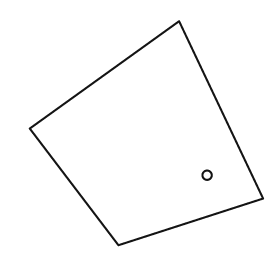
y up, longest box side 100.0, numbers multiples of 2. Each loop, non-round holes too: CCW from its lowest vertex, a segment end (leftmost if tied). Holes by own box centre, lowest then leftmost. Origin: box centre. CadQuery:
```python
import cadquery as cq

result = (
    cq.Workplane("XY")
    .moveTo(-12.0, -48.0)
    .lineTo(50.0, -28.0)
    .lineTo(14.0, 48.0)
    .lineTo(-50.0, 2.0)
    .close()
    .moveTo(26.0, -18.0)
    .circle(2.0)
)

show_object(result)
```